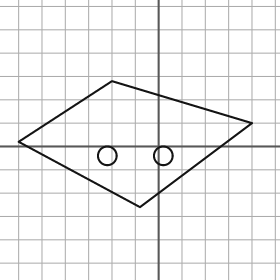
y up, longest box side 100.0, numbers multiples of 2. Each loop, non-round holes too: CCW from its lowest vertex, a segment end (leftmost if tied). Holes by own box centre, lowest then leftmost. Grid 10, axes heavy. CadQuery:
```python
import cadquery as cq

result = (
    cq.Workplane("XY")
    .moveTo(-8.0, -26.0)
    .lineTo(40.0, 10.0)
    .lineTo(-20.0, 28.0)
    .lineTo(-60.0, 2.0)
    .close()
    .moveTo(-22.0, -4.0)
    .circle(4.0)
    .moveTo(2.0, -4.0)
    .circle(4.0)
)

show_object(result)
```